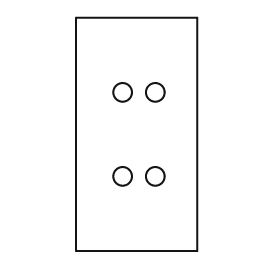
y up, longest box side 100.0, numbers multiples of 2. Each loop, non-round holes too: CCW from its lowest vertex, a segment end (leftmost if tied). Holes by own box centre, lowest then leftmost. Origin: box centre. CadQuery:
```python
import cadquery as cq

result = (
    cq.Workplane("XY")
    .moveTo(-26.0, -50.0)
    .lineTo(26.0, -50.0)
    .lineTo(26.0, 50.0)
    .lineTo(-26.0, 50.0)
    .close()
    .moveTo(-6.0, -18.0)
    .circle(4.0)
    .moveTo(8.0, -18.0)
    .circle(4.0)
    .moveTo(-6.0, 18.0)
    .circle(4.0)
    .moveTo(8.0, 18.0)
    .circle(4.0)
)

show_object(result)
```